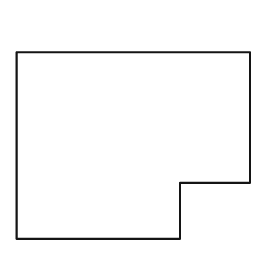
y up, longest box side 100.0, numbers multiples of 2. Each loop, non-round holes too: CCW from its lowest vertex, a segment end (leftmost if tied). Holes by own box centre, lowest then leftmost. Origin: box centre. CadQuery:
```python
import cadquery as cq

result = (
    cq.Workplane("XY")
    .moveTo(-50.0, -40.0)
    .lineTo(20.0, -40.0)
    .lineTo(20.0, -16.0)
    .lineTo(50.0, -16.0)
    .lineTo(50.0, 40.0)
    .lineTo(-50.0, 40.0)
    .close()
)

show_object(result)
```